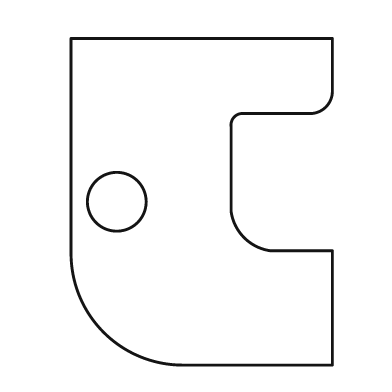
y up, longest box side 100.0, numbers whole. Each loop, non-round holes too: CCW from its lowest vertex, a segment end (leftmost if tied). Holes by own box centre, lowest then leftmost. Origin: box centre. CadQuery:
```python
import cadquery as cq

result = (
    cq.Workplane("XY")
    .moveTo(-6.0, -50.0)
    .lineTo(40.0, -50.0)
    .lineTo(40.0, -15.0)
    .lineTo(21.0, -15.0)
    .threePointArc((13.0, -11.0), (9.0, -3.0))
    .lineTo(9.0, 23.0)
    .threePointArc((10.0, 26.0), (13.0, 27.0))
    .lineTo(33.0, 27.0)
    .threePointArc((38.0, 29.0), (40.0, 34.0))
    .lineTo(40.0, 50.0)
    .lineTo(-40.0, 50.0)
    .lineTo(-40.0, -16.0)
    .threePointArc((-30.0, -40.0), (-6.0, -50.0))
    .close()
    .moveTo(-26.0, 0.0)
    .circle(9.0)
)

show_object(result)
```